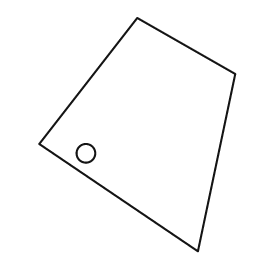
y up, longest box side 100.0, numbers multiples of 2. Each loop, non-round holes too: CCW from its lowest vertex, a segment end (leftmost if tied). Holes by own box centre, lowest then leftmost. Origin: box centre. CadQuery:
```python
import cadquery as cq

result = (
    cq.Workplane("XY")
    .moveTo(26.0, -50.0)
    .lineTo(42.0, 26.0)
    .lineTo(0.0, 50.0)
    .lineTo(-42.0, -4.0)
    .close()
    .moveTo(-22.0, -8.0)
    .circle(4.0)
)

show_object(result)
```